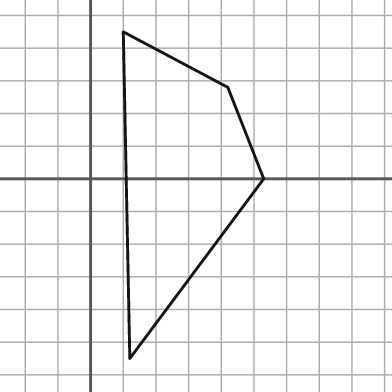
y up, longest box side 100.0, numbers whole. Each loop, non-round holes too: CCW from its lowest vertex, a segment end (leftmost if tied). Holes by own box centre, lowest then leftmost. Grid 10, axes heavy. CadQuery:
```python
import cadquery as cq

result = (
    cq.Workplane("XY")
    .moveTo(12.0, -55.0)
    .lineTo(53.0, 0.0)
    .lineTo(42.0, 28.0)
    .lineTo(10.0, 45.0)
    .close()
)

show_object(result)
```